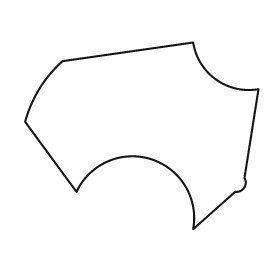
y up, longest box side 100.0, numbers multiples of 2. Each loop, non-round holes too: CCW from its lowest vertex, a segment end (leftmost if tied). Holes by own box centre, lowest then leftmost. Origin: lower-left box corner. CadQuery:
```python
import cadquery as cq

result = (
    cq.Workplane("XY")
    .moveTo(72.0, 0.0)
    .lineTo(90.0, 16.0)
    .threePointArc((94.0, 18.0), (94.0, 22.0))
    .lineTo(100.0, 60.0)
    .threePointArc((82.0, 64.0), (72.0, 80.0))
    .lineTo(16.0, 72.0)
    .threePointArc((6.0, 60.0), (0.0, 46.0))
    .lineTo(22.0, 16.0)
    .threePointArc((54.0, 30.0), (72.0, 0.0))
    .close()
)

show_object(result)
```